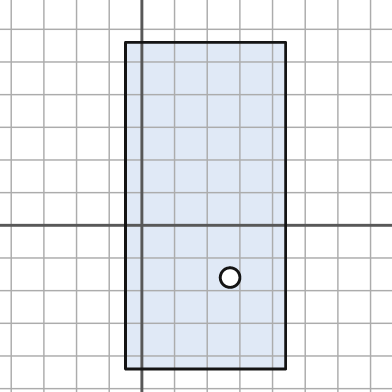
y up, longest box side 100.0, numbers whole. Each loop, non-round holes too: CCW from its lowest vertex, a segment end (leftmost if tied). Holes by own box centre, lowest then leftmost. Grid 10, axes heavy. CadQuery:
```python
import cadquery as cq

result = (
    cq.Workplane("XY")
    .moveTo(-5.0, -44.0)
    .lineTo(44.0, -44.0)
    .lineTo(44.0, 56.0)
    .lineTo(-5.0, 56.0)
    .close()
    .moveTo(27.0, -16.0)
    .circle(3.0)
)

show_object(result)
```